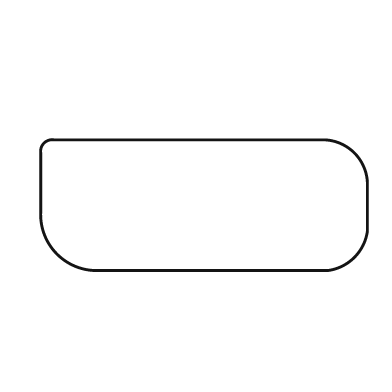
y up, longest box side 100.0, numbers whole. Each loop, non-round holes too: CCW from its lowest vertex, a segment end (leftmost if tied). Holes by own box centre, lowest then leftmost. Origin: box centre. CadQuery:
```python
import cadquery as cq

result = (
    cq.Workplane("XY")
    .moveTo(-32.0, -20.0)
    .lineTo(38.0, -20.0)
    .threePointArc((46.0, -16.0), (50.0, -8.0))
    .lineTo(50.0, 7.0)
    .threePointArc((46.0, 16.0), (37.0, 20.0))
    .lineTo(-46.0, 20.0)
    .threePointArc((-49.0, 19.0), (-50.0, 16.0))
    .lineTo(-50.0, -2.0)
    .threePointArc((-45.0, -15.0), (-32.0, -20.0))
    .close()
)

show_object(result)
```